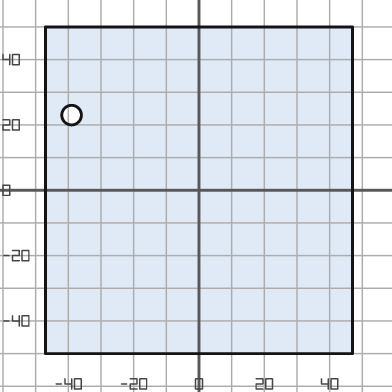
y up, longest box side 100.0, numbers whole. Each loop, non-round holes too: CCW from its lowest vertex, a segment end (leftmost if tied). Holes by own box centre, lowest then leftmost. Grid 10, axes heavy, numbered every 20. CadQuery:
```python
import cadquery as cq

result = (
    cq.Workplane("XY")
    .moveTo(-47.0, -50.0)
    .lineTo(47.0, -50.0)
    .lineTo(47.0, 50.0)
    .lineTo(-47.0, 50.0)
    .close()
    .moveTo(-39.0, 23.0)
    .circle(3.0)
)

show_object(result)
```